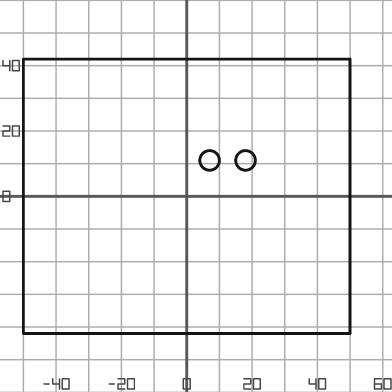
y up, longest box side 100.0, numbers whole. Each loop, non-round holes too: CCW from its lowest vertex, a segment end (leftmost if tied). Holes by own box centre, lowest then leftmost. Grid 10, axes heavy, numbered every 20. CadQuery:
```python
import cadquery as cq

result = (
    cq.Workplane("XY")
    .moveTo(-50.0, -42.0)
    .lineTo(50.0, -42.0)
    .lineTo(50.0, 42.0)
    .lineTo(-50.0, 42.0)
    .close()
    .moveTo(7.0, 11.0)
    .circle(3.0)
    .moveTo(18.0, 11.0)
    .circle(3.0)
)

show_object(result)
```